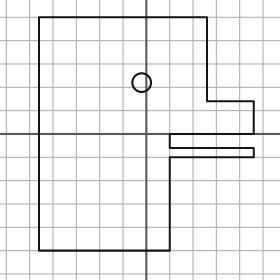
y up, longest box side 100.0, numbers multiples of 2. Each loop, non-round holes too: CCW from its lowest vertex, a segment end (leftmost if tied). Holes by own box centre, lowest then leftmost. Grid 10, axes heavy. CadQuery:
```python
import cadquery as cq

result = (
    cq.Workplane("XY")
    .moveTo(-46.0, -50.0)
    .lineTo(10.0, -50.0)
    .lineTo(10.0, -10.0)
    .lineTo(46.0, -10.0)
    .lineTo(46.0, -6.0)
    .lineTo(10.0, -6.0)
    .lineTo(10.0, 0.0)
    .lineTo(46.0, 0.0)
    .lineTo(46.0, 14.0)
    .lineTo(26.0, 14.0)
    .lineTo(26.0, 50.0)
    .lineTo(-46.0, 50.0)
    .close()
    .moveTo(-2.0, 22.0)
    .circle(4.0)
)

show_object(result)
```